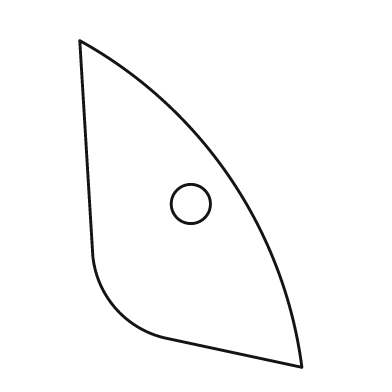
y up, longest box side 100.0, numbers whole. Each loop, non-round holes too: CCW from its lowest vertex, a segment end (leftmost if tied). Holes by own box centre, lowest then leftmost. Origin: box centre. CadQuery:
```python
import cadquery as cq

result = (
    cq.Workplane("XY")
    .moveTo(34.0, -50.0)
    .threePointArc((12.0, 8.0), (-34.0, 50.0))
    .lineTo(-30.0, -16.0)
    .threePointArc((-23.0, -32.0), (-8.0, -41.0))
    .close()
    .moveTo(0.0, 0.0)
    .circle(6.0)
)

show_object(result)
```